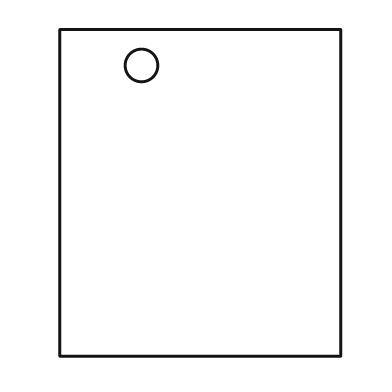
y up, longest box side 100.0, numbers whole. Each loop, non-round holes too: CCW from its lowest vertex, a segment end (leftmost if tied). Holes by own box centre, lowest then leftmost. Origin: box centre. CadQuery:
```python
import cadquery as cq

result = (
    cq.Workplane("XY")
    .moveTo(-43.0, -50.0)
    .lineTo(43.0, -50.0)
    .lineTo(43.0, 50.0)
    .lineTo(-43.0, 50.0)
    .close()
    .moveTo(-18.0, 39.0)
    .circle(5.0)
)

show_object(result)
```